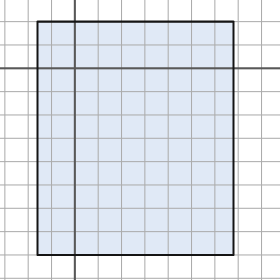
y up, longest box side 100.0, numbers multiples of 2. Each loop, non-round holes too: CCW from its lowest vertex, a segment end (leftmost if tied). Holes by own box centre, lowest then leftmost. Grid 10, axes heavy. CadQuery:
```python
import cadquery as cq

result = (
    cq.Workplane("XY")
    .moveTo(-16.0, -80.0)
    .lineTo(68.0, -80.0)
    .lineTo(68.0, 20.0)
    .lineTo(-16.0, 20.0)
    .close()
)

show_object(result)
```